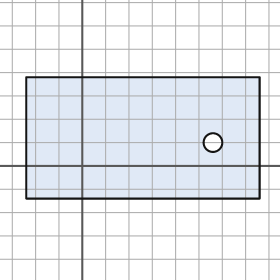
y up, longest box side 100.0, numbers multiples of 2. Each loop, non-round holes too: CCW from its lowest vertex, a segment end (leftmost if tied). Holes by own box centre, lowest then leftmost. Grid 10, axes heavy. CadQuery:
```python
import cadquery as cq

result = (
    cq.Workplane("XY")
    .moveTo(-24.0, -14.0)
    .lineTo(76.0, -14.0)
    .lineTo(76.0, 38.0)
    .lineTo(-24.0, 38.0)
    .close()
    .moveTo(56.0, 10.0)
    .circle(4.0)
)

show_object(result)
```